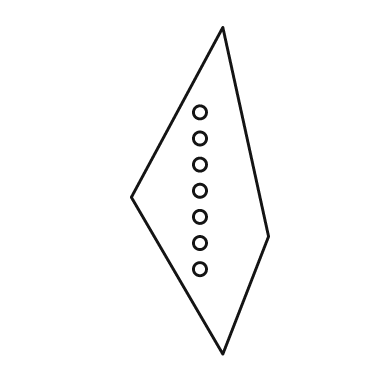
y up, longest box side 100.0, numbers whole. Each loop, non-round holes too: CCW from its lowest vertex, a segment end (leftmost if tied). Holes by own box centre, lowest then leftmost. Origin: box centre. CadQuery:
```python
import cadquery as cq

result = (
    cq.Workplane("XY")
    .moveTo(7.0, -50.0)
    .lineTo(21.0, -14.0)
    .lineTo(7.0, 50.0)
    .lineTo(-21.0, -2.0)
    .close()
    .moveTo(0.0, -24.0)
    .circle(2.0)
    .moveTo(0.0, -16.0)
    .circle(2.0)
    .moveTo(0.0, -8.0)
    .circle(2.0)
    .moveTo(0.0, 0.0)
    .circle(2.0)
    .moveTo(0.0, 8.0)
    .circle(2.0)
    .moveTo(0.0, 16.0)
    .circle(2.0)
    .moveTo(0.0, 24.0)
    .circle(2.0)
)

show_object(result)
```